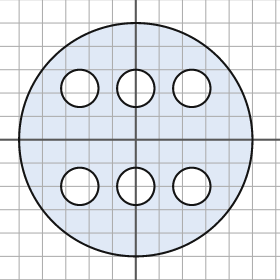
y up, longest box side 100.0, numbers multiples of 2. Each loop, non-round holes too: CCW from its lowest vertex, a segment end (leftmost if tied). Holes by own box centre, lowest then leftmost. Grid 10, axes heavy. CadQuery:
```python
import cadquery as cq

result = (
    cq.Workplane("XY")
    .moveTo(0.0, 0.0)
    .circle(50.0)
    .moveTo(-24.0, -20.0)
    .circle(8.0)
    .moveTo(0.0, -20.0)
    .circle(8.0)
    .moveTo(24.0, -20.0)
    .circle(8.0)
    .moveTo(-24.0, 22.0)
    .circle(8.0)
    .moveTo(0.0, 22.0)
    .circle(8.0)
    .moveTo(24.0, 22.0)
    .circle(8.0)
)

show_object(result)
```